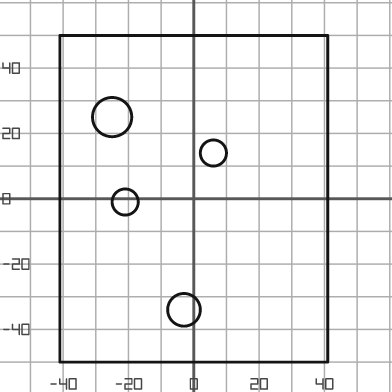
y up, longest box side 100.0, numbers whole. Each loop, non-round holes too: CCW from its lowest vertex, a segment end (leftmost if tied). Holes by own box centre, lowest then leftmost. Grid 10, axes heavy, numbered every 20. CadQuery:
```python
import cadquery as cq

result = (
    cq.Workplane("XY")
    .moveTo(-41.0, -50.0)
    .lineTo(41.0, -50.0)
    .lineTo(41.0, 50.0)
    .lineTo(-41.0, 50.0)
    .close()
    .moveTo(-3.0, -34.0)
    .circle(5.0)
    .moveTo(-21.0, -1.0)
    .circle(4.0)
    .moveTo(6.0, 14.0)
    .circle(4.0)
    .moveTo(-25.0, 25.0)
    .circle(6.0)
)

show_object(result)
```